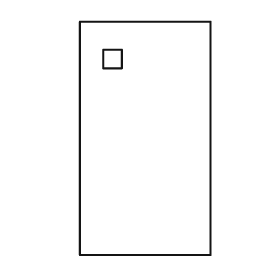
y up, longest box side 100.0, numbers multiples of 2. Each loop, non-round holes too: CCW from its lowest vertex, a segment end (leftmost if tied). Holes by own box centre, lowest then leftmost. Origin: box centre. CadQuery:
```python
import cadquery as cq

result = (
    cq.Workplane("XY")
    .moveTo(-28.0, -50.0)
    .lineTo(28.0, -50.0)
    .lineTo(28.0, 50.0)
    .lineTo(-28.0, 50.0)
    .close()
    .moveTo(-18.0, 30.0)
    .lineTo(-10.0, 30.0)
    .lineTo(-10.0, 38.0)
    .lineTo(-18.0, 38.0)
    .close()
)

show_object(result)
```